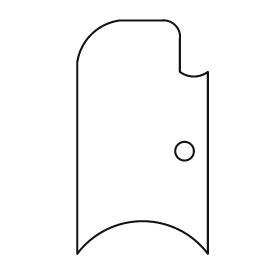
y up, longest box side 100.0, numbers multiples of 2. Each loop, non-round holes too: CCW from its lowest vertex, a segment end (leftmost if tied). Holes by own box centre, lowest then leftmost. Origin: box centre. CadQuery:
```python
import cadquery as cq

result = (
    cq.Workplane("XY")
    .moveTo(-28.0, -50.0)
    .threePointArc((0.0, -36.0), (28.0, -50.0))
    .lineTo(28.0, 28.0)
    .threePointArc((22.0, 26.0), (16.0, 28.0))
    .lineTo(16.0, 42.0)
    .threePointArc((14.0, 48.0), (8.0, 50.0))
    .lineTo(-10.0, 50.0)
    .threePointArc((-22.0, 44.0), (-28.0, 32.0))
    .close()
    .moveTo(18.0, -6.0)
    .circle(4.0)
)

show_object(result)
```